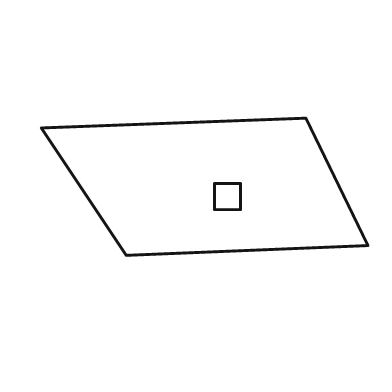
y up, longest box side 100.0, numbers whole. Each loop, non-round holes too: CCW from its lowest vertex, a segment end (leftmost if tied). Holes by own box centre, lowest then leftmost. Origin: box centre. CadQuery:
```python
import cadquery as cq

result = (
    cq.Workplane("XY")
    .moveTo(-24.0, -21.0)
    .lineTo(50.0, -18.0)
    .lineTo(31.0, 21.0)
    .lineTo(-50.0, 18.0)
    .close()
    .moveTo(3.0, -7.0)
    .lineTo(11.0, -7.0)
    .lineTo(11.0, 1.0)
    .lineTo(3.0, 1.0)
    .close()
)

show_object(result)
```